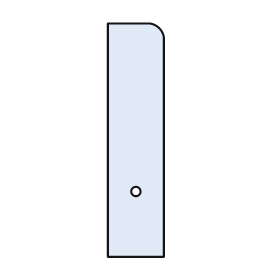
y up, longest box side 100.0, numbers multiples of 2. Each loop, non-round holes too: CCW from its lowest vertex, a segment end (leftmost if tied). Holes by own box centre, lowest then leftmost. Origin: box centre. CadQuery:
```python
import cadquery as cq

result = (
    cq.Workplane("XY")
    .moveTo(-12.0, -50.0)
    .lineTo(12.0, -50.0)
    .lineTo(12.0, 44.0)
    .threePointArc((10.0, 48.0), (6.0, 50.0))
    .lineTo(-12.0, 50.0)
    .close()
    .moveTo(0.0, -22.0)
    .circle(2.0)
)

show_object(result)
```